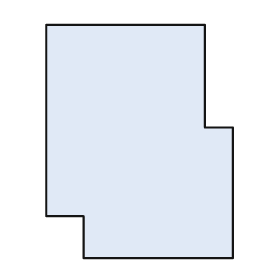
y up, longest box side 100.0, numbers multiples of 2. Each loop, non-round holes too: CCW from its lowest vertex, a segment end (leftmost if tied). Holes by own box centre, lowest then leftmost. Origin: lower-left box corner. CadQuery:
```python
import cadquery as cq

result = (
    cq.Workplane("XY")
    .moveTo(16.0, 0.0)
    .lineTo(80.0, 0.0)
    .lineTo(80.0, 56.0)
    .lineTo(68.0, 56.0)
    .lineTo(68.0, 100.0)
    .lineTo(0.0, 100.0)
    .lineTo(0.0, 18.0)
    .lineTo(16.0, 18.0)
    .close()
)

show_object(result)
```